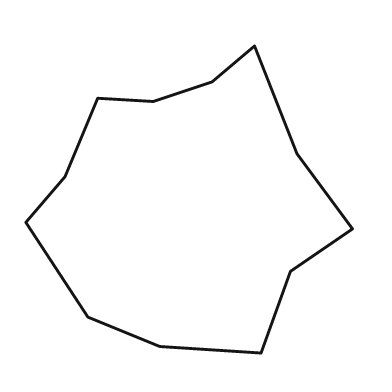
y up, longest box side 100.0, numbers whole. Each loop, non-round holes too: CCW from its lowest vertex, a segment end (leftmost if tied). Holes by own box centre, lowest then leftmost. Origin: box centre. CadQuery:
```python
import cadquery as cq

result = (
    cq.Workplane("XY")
    .moveTo(22.0, -47.0)
    .lineTo(31.0, -22.0)
    .lineTo(50.0, -9.0)
    .lineTo(33.0, 14.0)
    .lineTo(20.0, 47.0)
    .lineTo(7.0, 36.0)
    .lineTo(-11.0, 30.0)
    .lineTo(-28.0, 31.0)
    .lineTo(-38.0, 7.0)
    .lineTo(-50.0, -7.0)
    .lineTo(-31.0, -36.0)
    .lineTo(-9.0, -45.0)
    .close()
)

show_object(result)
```